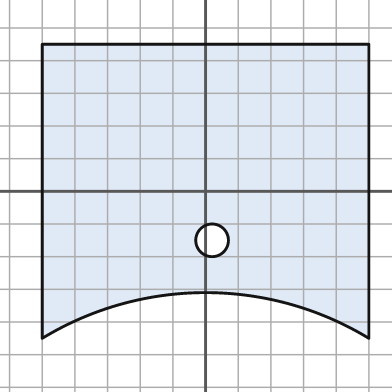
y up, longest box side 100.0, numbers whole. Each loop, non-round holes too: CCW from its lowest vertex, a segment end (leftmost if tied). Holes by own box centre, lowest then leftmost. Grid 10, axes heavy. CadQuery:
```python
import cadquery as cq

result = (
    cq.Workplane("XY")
    .moveTo(-50.0, -45.0)
    .threePointArc((0.0, -31.0), (50.0, -45.0))
    .lineTo(50.0, 45.0)
    .lineTo(-50.0, 45.0)
    .close()
    .moveTo(2.0, -15.0)
    .circle(5.0)
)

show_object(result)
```